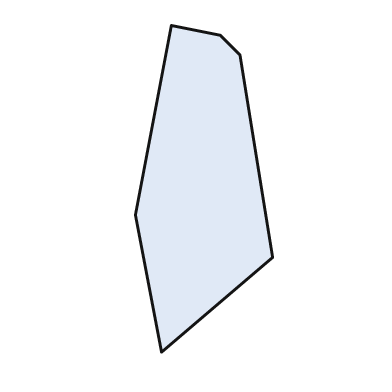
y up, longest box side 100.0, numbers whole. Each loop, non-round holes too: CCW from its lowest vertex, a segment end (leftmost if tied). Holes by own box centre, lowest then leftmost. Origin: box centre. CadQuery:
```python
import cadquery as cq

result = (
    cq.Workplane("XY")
    .moveTo(-13.0, -50.0)
    .lineTo(21.0, -21.0)
    .lineTo(11.0, 41.0)
    .lineTo(5.0, 47.0)
    .lineTo(-10.0, 50.0)
    .lineTo(-21.0, -8.0)
    .close()
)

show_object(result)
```